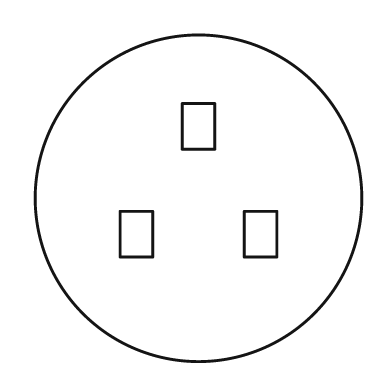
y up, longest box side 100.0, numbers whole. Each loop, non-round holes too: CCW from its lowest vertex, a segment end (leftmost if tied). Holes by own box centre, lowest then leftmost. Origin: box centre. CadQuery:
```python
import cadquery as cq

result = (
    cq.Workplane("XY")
    .moveTo(0.0, 0.0)
    .circle(50.0)
    .moveTo(-24.0, -18.0)
    .lineTo(-14.0, -18.0)
    .lineTo(-14.0, -4.0)
    .lineTo(-24.0, -4.0)
    .close()
    .moveTo(14.0, -18.0)
    .lineTo(24.0, -18.0)
    .lineTo(24.0, -4.0)
    .lineTo(14.0, -4.0)
    .close()
    .moveTo(-5.0, 15.0)
    .lineTo(5.0, 15.0)
    .lineTo(5.0, 29.0)
    .lineTo(-5.0, 29.0)
    .close()
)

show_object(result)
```